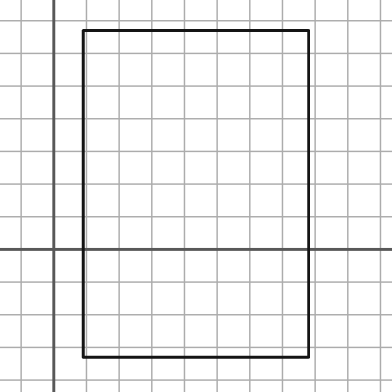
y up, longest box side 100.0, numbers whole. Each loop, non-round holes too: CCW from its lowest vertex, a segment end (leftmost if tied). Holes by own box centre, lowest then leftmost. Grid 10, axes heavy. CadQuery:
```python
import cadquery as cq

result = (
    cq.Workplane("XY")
    .moveTo(9.0, -33.0)
    .lineTo(78.0, -33.0)
    .lineTo(78.0, 67.0)
    .lineTo(9.0, 67.0)
    .close()
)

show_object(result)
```